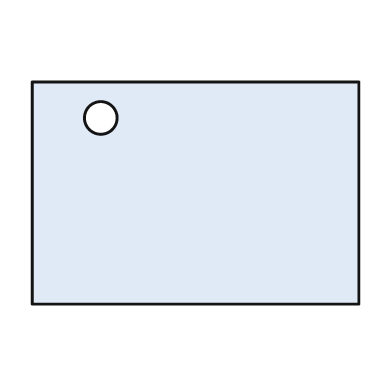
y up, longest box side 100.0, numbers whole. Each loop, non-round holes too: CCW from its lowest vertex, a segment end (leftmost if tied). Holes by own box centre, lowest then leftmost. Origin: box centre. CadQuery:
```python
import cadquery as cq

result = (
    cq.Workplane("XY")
    .moveTo(-50.0, -34.0)
    .lineTo(50.0, -34.0)
    .lineTo(50.0, 34.0)
    .lineTo(-50.0, 34.0)
    .close()
    .moveTo(-29.0, 23.0)
    .circle(5.0)
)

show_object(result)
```